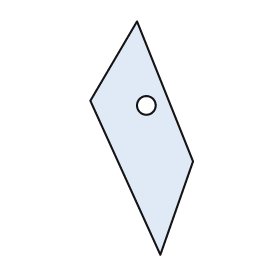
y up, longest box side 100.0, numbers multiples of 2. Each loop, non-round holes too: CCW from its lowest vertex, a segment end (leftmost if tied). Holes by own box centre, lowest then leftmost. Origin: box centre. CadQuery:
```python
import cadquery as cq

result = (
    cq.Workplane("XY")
    .moveTo(8.0, -50.0)
    .lineTo(22.0, -10.0)
    .lineTo(-2.0, 50.0)
    .lineTo(-22.0, 16.0)
    .close()
    .moveTo(2.0, 14.0)
    .circle(4.0)
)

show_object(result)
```